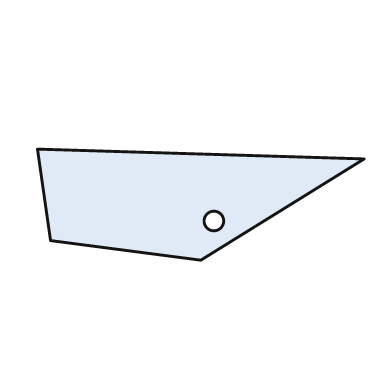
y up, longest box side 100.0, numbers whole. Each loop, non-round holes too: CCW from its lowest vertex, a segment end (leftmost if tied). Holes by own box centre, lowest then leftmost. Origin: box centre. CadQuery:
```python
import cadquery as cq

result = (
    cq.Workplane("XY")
    .moveTo(0.0, -17.0)
    .lineTo(50.0, 14.0)
    .lineTo(-50.0, 17.0)
    .lineTo(-46.0, -11.0)
    .close()
    .moveTo(4.0, -5.0)
    .circle(3.0)
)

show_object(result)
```